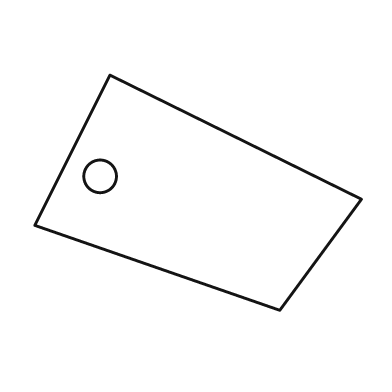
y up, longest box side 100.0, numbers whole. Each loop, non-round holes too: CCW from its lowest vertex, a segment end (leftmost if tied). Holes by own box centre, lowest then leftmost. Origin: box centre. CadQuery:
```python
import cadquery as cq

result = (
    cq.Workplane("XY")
    .moveTo(25.0, -36.0)
    .lineTo(50.0, -2.0)
    .lineTo(-27.0, 36.0)
    .lineTo(-50.0, -10.0)
    .close()
    .moveTo(-30.0, 5.0)
    .circle(5.0)
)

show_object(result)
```